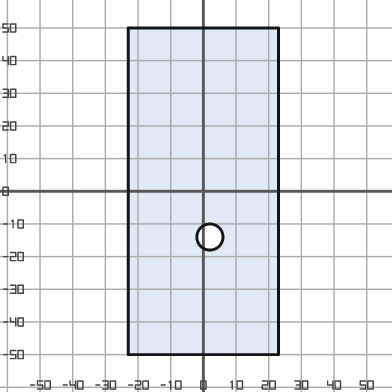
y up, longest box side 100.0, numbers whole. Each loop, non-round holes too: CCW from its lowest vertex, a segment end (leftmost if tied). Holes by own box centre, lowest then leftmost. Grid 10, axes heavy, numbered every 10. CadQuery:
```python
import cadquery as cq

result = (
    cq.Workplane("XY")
    .moveTo(-23.0, -50.0)
    .lineTo(23.0, -50.0)
    .lineTo(23.0, 50.0)
    .lineTo(-23.0, 50.0)
    .close()
    .moveTo(2.0, -14.0)
    .circle(4.0)
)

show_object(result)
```